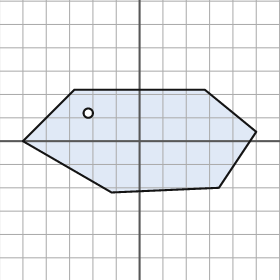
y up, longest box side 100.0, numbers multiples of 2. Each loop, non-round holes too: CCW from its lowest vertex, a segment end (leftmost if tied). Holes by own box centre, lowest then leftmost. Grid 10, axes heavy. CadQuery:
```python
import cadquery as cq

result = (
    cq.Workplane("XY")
    .moveTo(-12.0, -22.0)
    .lineTo(34.0, -20.0)
    .lineTo(50.0, 4.0)
    .lineTo(28.0, 22.0)
    .lineTo(-28.0, 22.0)
    .lineTo(-50.0, 0.0)
    .close()
    .moveTo(-22.0, 12.0)
    .circle(2.0)
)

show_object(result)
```